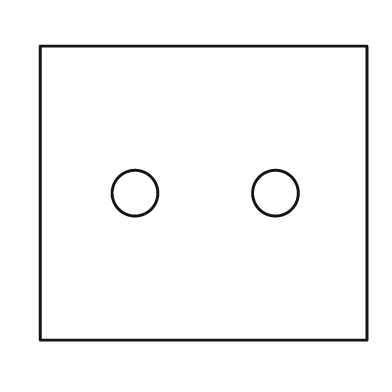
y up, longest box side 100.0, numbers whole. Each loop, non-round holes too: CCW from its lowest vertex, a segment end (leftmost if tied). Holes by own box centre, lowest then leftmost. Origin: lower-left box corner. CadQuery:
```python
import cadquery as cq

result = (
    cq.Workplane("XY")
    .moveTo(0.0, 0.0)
    .lineTo(100.0, 0.0)
    .lineTo(100.0, 90.0)
    .lineTo(0.0, 90.0)
    .close()
    .moveTo(29.0, 45.0)
    .circle(7.0)
    .moveTo(72.0, 45.0)
    .circle(7.0)
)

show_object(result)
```